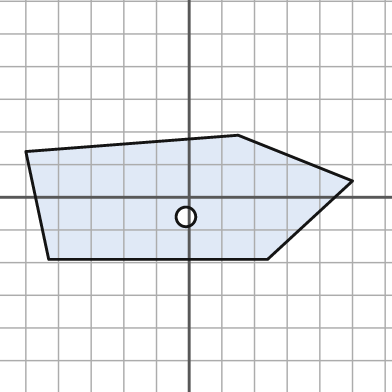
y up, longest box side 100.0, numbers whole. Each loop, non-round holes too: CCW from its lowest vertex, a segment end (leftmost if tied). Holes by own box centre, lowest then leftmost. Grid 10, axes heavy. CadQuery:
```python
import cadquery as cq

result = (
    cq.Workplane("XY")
    .moveTo(-43.0, -19.0)
    .lineTo(24.0, -19.0)
    .lineTo(50.0, 5.0)
    .lineTo(15.0, 19.0)
    .lineTo(-50.0, 14.0)
    .close()
    .moveTo(-1.0, -6.0)
    .circle(3.0)
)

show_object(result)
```